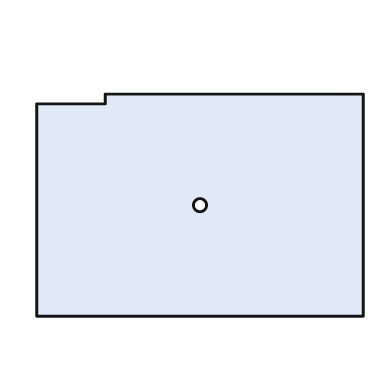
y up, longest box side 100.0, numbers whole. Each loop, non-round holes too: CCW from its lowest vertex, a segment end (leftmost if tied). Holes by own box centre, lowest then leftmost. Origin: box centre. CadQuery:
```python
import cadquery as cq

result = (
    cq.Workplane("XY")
    .moveTo(-50.0, -34.0)
    .lineTo(50.0, -34.0)
    .lineTo(50.0, 34.0)
    .lineTo(-29.0, 34.0)
    .lineTo(-29.0, 31.0)
    .lineTo(-50.0, 31.0)
    .close()
    .moveTo(0.0, 0.0)
    .circle(2.0)
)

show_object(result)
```